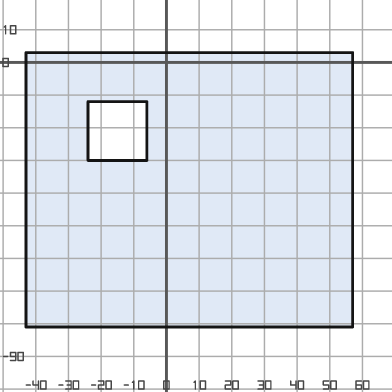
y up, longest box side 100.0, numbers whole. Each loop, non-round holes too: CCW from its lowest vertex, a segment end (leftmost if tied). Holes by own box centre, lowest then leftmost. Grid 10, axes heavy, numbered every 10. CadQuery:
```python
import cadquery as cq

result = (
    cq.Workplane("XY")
    .moveTo(-43.0, -81.0)
    .lineTo(57.0, -81.0)
    .lineTo(57.0, 3.0)
    .lineTo(-43.0, 3.0)
    .close()
    .moveTo(-24.0, -30.0)
    .lineTo(-6.0, -30.0)
    .lineTo(-6.0, -12.0)
    .lineTo(-24.0, -12.0)
    .close()
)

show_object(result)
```